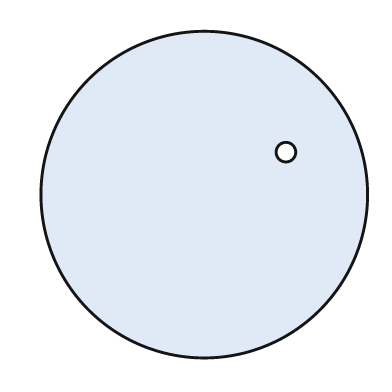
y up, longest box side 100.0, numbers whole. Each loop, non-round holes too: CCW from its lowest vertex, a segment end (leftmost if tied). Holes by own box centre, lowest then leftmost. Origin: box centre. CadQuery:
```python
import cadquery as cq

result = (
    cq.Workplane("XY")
    .moveTo(0.0, 0.0)
    .circle(50.0)
    .moveTo(25.0, 13.0)
    .circle(3.0)
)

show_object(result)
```